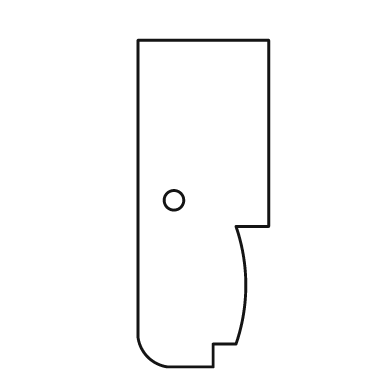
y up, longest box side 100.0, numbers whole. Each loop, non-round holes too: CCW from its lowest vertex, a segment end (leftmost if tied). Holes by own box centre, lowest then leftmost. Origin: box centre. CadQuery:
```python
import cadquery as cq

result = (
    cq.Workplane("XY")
    .moveTo(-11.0, -50.0)
    .lineTo(3.0, -50.0)
    .lineTo(3.0, -43.0)
    .lineTo(10.0, -43.0)
    .threePointArc((13.0, -25.0), (10.0, -7.0))
    .lineTo(20.0, -7.0)
    .lineTo(20.0, 50.0)
    .lineTo(-20.0, 50.0)
    .lineTo(-20.0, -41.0)
    .threePointArc((-17.0, -47.0), (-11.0, -50.0))
    .close()
    .moveTo(-9.0, 1.0)
    .circle(3.0)
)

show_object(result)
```